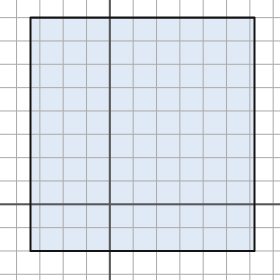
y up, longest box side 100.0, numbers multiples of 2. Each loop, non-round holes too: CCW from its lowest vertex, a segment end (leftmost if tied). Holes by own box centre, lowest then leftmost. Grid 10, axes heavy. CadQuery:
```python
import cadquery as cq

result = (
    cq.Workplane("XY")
    .moveTo(-34.0, -20.0)
    .lineTo(62.0, -20.0)
    .lineTo(62.0, 80.0)
    .lineTo(-34.0, 80.0)
    .close()
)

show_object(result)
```